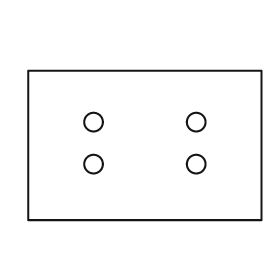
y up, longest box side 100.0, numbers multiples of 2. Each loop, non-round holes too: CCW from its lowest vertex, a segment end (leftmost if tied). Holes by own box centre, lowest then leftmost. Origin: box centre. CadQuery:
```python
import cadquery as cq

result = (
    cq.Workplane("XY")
    .moveTo(-50.0, -32.0)
    .lineTo(50.0, -32.0)
    .lineTo(50.0, 32.0)
    .lineTo(-50.0, 32.0)
    .close()
    .moveTo(-22.0, -8.0)
    .circle(4.0)
    .moveTo(22.0, -8.0)
    .circle(4.0)
    .moveTo(-22.0, 10.0)
    .circle(4.0)
    .moveTo(22.0, 10.0)
    .circle(4.0)
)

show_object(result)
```